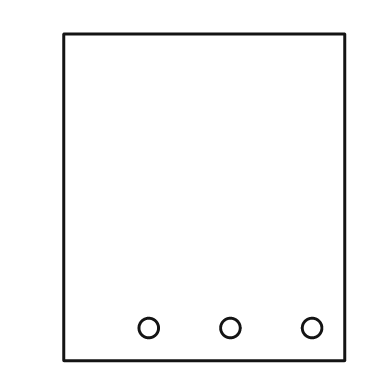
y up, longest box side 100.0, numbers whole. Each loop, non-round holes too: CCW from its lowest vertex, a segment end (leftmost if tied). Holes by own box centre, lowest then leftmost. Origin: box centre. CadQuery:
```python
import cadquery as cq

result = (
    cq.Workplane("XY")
    .moveTo(-43.0, -50.0)
    .lineTo(43.0, -50.0)
    .lineTo(43.0, 50.0)
    .lineTo(-43.0, 50.0)
    .close()
    .moveTo(-17.0, -40.0)
    .circle(3.0)
    .moveTo(8.0, -40.0)
    .circle(3.0)
    .moveTo(33.0, -40.0)
    .circle(3.0)
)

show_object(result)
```